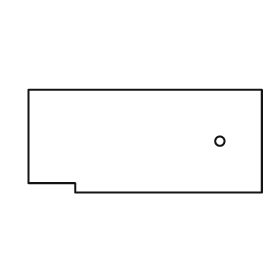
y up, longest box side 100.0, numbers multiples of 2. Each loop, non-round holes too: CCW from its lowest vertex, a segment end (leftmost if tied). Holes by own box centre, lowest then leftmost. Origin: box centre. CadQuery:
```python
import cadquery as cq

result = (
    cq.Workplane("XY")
    .moveTo(-30.0, -22.0)
    .lineTo(50.0, -22.0)
    .lineTo(50.0, 22.0)
    .lineTo(-50.0, 22.0)
    .lineTo(-50.0, -18.0)
    .lineTo(-30.0, -18.0)
    .close()
    .moveTo(32.0, 0.0)
    .circle(2.0)
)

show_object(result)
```